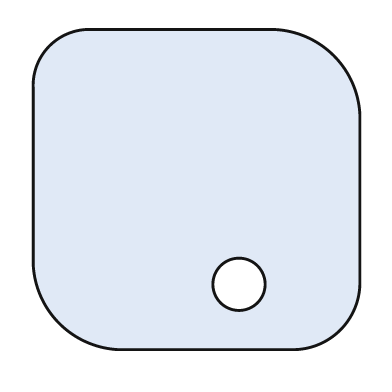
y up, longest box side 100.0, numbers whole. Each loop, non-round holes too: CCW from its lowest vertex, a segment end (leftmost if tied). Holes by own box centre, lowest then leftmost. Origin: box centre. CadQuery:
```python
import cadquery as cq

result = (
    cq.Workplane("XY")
    .moveTo(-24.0, -49.0)
    .lineTo(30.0, -49.0)
    .threePointArc((44.0, -43.0), (50.0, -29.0))
    .lineTo(50.0, 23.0)
    .threePointArc((42.0, 41.0), (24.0, 49.0))
    .lineTo(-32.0, 49.0)
    .threePointArc((-45.0, 44.0), (-50.0, 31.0))
    .lineTo(-50.0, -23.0)
    .threePointArc((-42.0, -41.0), (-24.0, -49.0))
    .close()
    .moveTo(13.0, -29.0)
    .circle(8.0)
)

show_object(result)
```